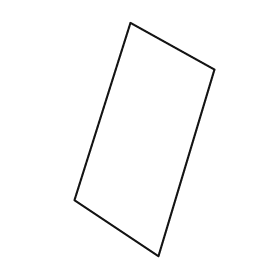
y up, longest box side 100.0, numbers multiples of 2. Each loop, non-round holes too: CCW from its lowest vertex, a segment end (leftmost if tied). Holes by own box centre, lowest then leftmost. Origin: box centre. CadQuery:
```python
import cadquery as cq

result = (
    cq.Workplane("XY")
    .moveTo(6.0, -50.0)
    .lineTo(30.0, 30.0)
    .lineTo(-6.0, 50.0)
    .lineTo(-30.0, -26.0)
    .close()
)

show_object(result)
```